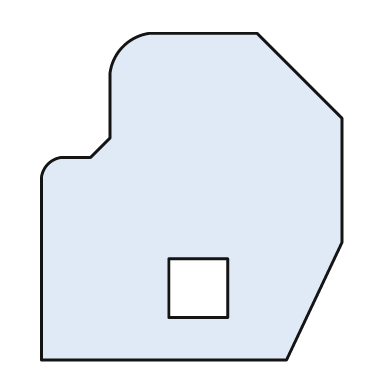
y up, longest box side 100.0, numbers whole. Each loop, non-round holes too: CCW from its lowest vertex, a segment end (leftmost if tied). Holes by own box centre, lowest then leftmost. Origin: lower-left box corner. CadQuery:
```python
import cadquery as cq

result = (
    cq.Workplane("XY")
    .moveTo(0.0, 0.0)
    .lineTo(75.0, 0.0)
    .lineTo(92.0, 36.0)
    .lineTo(92.0, 74.0)
    .lineTo(66.0, 100.0)
    .lineTo(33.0, 100.0)
    .threePointArc((25.0, 96.0), (21.0, 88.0))
    .lineTo(21.0, 68.0)
    .lineTo(15.0, 62.0)
    .lineTo(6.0, 62.0)
    .threePointArc((2.0, 60.0), (0.0, 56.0))
    .close()
    .moveTo(39.0, 13.0)
    .lineTo(57.0, 13.0)
    .lineTo(57.0, 31.0)
    .lineTo(39.0, 31.0)
    .close()
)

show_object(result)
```